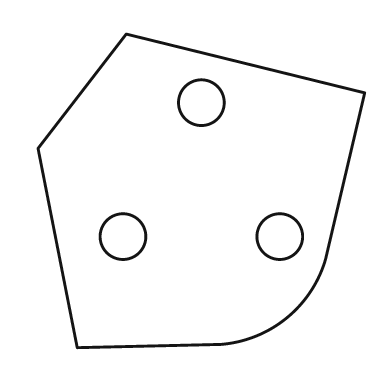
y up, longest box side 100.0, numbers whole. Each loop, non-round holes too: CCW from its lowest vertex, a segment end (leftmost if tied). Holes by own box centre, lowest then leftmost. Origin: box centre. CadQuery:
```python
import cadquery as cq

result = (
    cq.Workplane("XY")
    .moveTo(-38.0, -48.0)
    .lineTo(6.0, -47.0)
    .threePointArc((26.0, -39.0), (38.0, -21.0))
    .lineTo(50.0, 30.0)
    .lineTo(-23.0, 48.0)
    .lineTo(-50.0, 13.0)
    .close()
    .moveTo(-24.0, -14.0)
    .circle(7.0)
    .moveTo(24.0, -14.0)
    .circle(7.0)
    .moveTo(0.0, 27.0)
    .circle(7.0)
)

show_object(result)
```